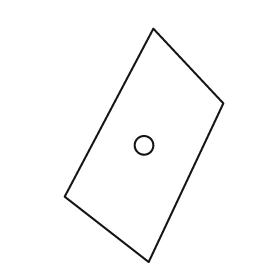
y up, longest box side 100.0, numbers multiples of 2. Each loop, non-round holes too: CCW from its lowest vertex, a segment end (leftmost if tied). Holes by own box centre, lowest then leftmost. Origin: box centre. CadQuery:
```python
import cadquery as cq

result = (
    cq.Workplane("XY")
    .moveTo(2.0, -50.0)
    .lineTo(34.0, 18.0)
    .lineTo(4.0, 50.0)
    .lineTo(-34.0, -22.0)
    .close()
    .moveTo(0.0, 0.0)
    .circle(4.0)
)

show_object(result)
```